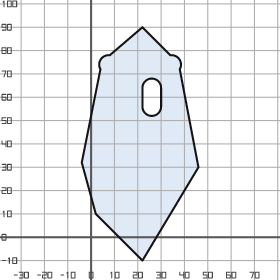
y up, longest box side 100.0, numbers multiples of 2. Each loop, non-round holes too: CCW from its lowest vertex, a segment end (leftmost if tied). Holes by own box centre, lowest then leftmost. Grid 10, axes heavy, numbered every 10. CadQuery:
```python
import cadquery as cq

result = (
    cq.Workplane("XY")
    .moveTo(22.0, -10.0)
    .lineTo(46.0, 30.0)
    .lineTo(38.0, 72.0)
    .threePointArc((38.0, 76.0), (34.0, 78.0))
    .lineTo(22.0, 90.0)
    .lineTo(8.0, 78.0)
    .threePointArc((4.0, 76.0), (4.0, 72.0))
    .lineTo(-4.0, 32.0)
    .lineTo(2.0, 10.0)
    .close()
    .moveTo(22.0, 56.0)
    .threePointArc((26.0, 52.0), (30.0, 56.0))
    .lineTo(30.0, 64.0)
    .threePointArc((26.0, 68.0), (22.0, 64.0))
    .close()
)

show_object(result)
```